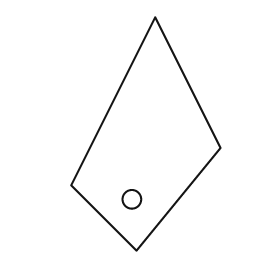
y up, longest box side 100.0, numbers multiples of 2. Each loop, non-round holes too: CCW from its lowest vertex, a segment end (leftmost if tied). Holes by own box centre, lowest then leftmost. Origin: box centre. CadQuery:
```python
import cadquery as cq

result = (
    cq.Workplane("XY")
    .moveTo(-4.0, -50.0)
    .lineTo(32.0, -6.0)
    .lineTo(4.0, 50.0)
    .lineTo(-32.0, -22.0)
    .close()
    .moveTo(-6.0, -28.0)
    .circle(4.0)
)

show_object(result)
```